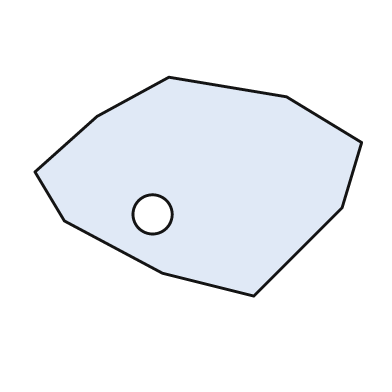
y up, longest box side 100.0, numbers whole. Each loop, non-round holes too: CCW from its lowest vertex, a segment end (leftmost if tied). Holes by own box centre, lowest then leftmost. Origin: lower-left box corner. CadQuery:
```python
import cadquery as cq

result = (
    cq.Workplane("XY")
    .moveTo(67.0, 0.0)
    .lineTo(94.0, 27.0)
    .lineTo(100.0, 47.0)
    .lineTo(77.0, 61.0)
    .lineTo(41.0, 67.0)
    .lineTo(19.0, 55.0)
    .lineTo(0.0, 38.0)
    .lineTo(9.0, 23.0)
    .lineTo(39.0, 7.0)
    .close()
    .moveTo(36.0, 25.0)
    .circle(6.0)
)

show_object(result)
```